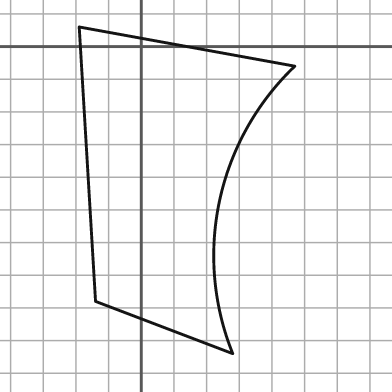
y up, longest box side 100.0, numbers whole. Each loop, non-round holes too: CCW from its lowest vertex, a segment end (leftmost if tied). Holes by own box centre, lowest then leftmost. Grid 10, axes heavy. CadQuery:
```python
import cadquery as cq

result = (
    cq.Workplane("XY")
    .moveTo(28.0, -94.0)
    .threePointArc((24.0, -47.0), (47.0, -6.0))
    .lineTo(-19.0, 6.0)
    .lineTo(-14.0, -78.0)
    .close()
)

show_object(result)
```